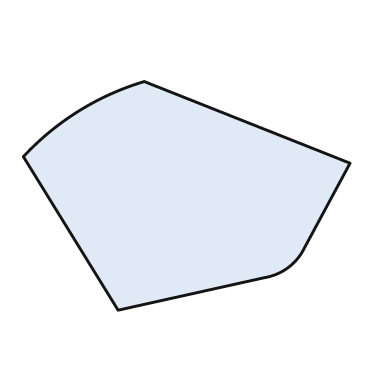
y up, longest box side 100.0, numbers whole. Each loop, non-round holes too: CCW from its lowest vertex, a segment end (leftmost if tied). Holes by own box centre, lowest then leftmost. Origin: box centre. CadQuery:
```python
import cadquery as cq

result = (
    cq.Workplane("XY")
    .moveTo(-21.0, -35.0)
    .lineTo(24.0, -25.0)
    .threePointArc((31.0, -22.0), (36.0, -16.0))
    .lineTo(50.0, 10.0)
    .lineTo(-13.0, 35.0)
    .threePointArc((-33.0, 26.0), (-50.0, 12.0))
    .close()
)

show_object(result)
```